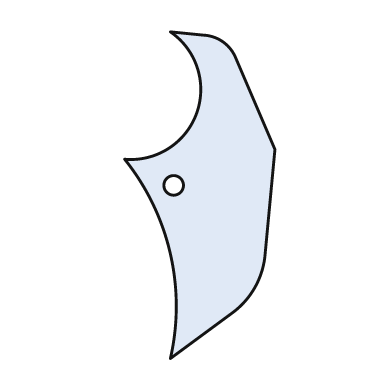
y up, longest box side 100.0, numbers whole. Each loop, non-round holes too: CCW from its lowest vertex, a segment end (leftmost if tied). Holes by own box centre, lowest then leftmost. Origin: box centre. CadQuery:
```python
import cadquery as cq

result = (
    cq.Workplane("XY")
    .moveTo(-9.0, -50.0)
    .lineTo(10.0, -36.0)
    .threePointArc((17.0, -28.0), (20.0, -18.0))
    .lineTo(23.0, 14.0)
    .lineTo(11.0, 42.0)
    .threePointArc((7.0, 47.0), (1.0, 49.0))
    .lineTo(-9.0, 50.0)
    .threePointArc((-1.0, 25.0), (-23.0, 11.0))
    .threePointArc((-9.0, -18.0), (-9.0, -50.0))
    .close()
    .moveTo(-8.0, 3.0)
    .circle(3.0)
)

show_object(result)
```